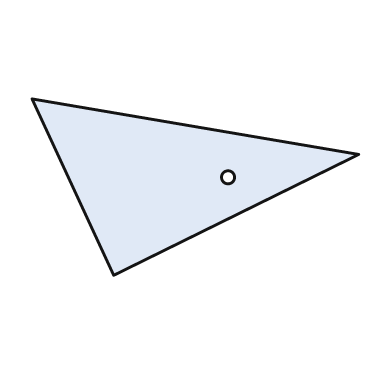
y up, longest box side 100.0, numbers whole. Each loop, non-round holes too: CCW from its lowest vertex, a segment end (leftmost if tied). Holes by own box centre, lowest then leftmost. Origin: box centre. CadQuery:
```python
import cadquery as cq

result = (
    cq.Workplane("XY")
    .moveTo(-25.0, -27.0)
    .lineTo(50.0, 10.0)
    .lineTo(-50.0, 27.0)
    .close()
    .moveTo(10.0, 3.0)
    .circle(2.0)
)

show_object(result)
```